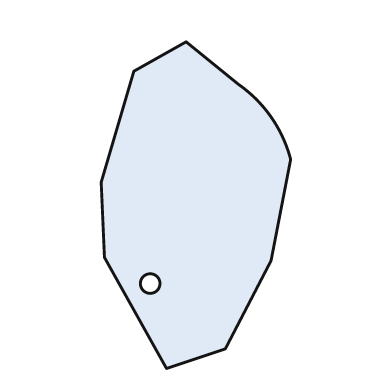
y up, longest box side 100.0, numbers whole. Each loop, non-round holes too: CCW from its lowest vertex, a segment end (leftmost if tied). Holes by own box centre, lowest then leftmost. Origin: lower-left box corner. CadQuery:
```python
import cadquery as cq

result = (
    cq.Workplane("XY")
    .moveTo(20.0, 0.0)
    .lineTo(38.0, 6.0)
    .lineTo(52.0, 33.0)
    .lineTo(58.0, 64.0)
    .threePointArc((52.0, 77.0), (42.0, 87.0))
    .lineTo(26.0, 100.0)
    .lineTo(10.0, 91.0)
    .lineTo(0.0, 57.0)
    .lineTo(1.0, 34.0)
    .close()
    .moveTo(15.0, 26.0)
    .circle(3.0)
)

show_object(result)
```